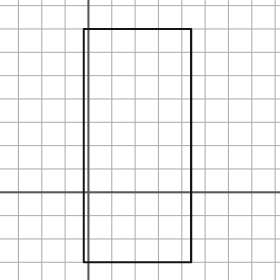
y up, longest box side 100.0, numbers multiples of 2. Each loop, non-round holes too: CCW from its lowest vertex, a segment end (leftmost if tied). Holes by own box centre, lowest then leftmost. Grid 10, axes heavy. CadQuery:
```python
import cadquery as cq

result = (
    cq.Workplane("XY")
    .moveTo(-2.0, -30.0)
    .lineTo(44.0, -30.0)
    .lineTo(44.0, 70.0)
    .lineTo(-2.0, 70.0)
    .close()
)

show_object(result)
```